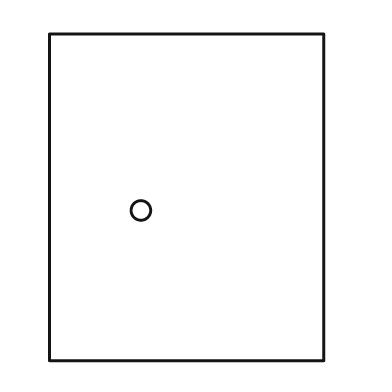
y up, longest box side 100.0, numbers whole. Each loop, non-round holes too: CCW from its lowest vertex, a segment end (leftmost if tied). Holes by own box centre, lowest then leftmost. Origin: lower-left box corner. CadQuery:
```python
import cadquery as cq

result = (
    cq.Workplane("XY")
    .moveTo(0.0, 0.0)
    .lineTo(84.0, 0.0)
    .lineTo(84.0, 100.0)
    .lineTo(0.0, 100.0)
    .close()
    .moveTo(28.0, 46.0)
    .circle(3.0)
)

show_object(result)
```